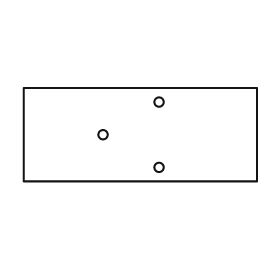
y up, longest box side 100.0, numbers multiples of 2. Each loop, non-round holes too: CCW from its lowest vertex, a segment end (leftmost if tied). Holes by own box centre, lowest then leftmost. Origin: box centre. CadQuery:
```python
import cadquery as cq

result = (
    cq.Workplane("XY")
    .moveTo(-50.0, -20.0)
    .lineTo(50.0, -20.0)
    .lineTo(50.0, 20.0)
    .lineTo(-50.0, 20.0)
    .close()
    .moveTo(8.0, -14.0)
    .circle(2.0)
    .moveTo(-16.0, 0.0)
    .circle(2.0)
    .moveTo(8.0, 14.0)
    .circle(2.0)
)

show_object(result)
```